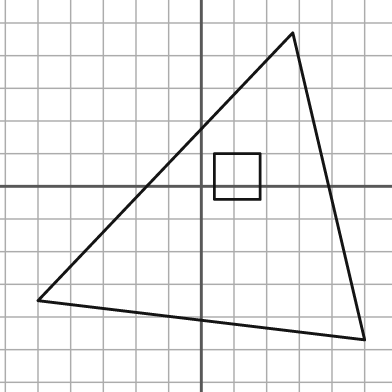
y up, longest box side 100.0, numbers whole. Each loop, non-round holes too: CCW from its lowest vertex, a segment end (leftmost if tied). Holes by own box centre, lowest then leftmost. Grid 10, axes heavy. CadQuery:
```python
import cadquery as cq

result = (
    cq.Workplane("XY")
    .moveTo(50.0, -47.0)
    .lineTo(28.0, 47.0)
    .lineTo(-50.0, -35.0)
    .close()
    .moveTo(4.0, -4.0)
    .lineTo(18.0, -4.0)
    .lineTo(18.0, 10.0)
    .lineTo(4.0, 10.0)
    .close()
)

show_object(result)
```